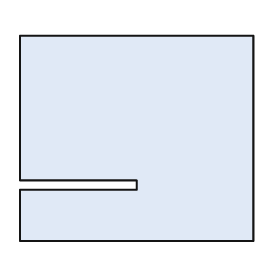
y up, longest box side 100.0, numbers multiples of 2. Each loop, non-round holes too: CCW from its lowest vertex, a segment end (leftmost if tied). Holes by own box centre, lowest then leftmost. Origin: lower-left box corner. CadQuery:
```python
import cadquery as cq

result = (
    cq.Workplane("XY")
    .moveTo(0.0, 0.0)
    .lineTo(100.0, 0.0)
    .lineTo(100.0, 88.0)
    .lineTo(0.0, 88.0)
    .lineTo(0.0, 26.0)
    .lineTo(50.0, 26.0)
    .lineTo(50.0, 22.0)
    .lineTo(0.0, 22.0)
    .close()
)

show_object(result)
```